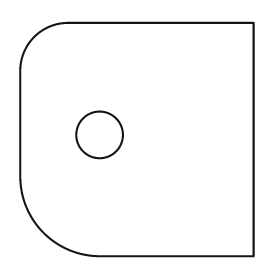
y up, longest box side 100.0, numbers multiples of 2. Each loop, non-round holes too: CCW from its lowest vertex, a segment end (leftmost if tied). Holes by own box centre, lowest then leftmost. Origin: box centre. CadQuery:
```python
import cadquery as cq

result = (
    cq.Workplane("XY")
    .moveTo(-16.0, -50.0)
    .lineTo(50.0, -50.0)
    .lineTo(50.0, 50.0)
    .lineTo(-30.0, 50.0)
    .threePointArc((-44.0, 44.0), (-50.0, 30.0))
    .lineTo(-50.0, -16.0)
    .threePointArc((-40.0, -40.0), (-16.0, -50.0))
    .close()
    .moveTo(-16.0, 2.0)
    .circle(10.0)
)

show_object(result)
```